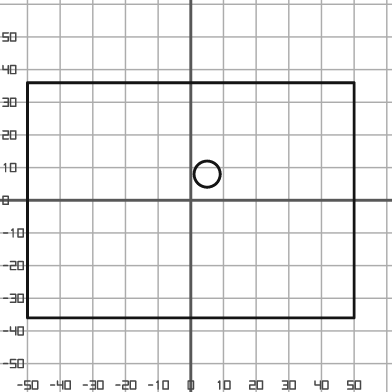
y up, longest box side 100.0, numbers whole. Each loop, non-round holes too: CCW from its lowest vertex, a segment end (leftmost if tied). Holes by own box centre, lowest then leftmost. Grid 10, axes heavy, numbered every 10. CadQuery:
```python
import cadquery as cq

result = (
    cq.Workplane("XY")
    .moveTo(-50.0, -36.0)
    .lineTo(50.0, -36.0)
    .lineTo(50.0, 36.0)
    .lineTo(-50.0, 36.0)
    .close()
    .moveTo(5.0, 8.0)
    .circle(4.0)
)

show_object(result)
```